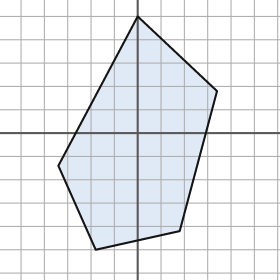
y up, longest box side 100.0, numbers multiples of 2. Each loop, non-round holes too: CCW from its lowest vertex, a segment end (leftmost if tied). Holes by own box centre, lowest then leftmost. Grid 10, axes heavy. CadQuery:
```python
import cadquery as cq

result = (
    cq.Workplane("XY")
    .moveTo(-18.0, -50.0)
    .lineTo(18.0, -42.0)
    .lineTo(34.0, 18.0)
    .lineTo(0.0, 50.0)
    .lineTo(-34.0, -14.0)
    .close()
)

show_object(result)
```